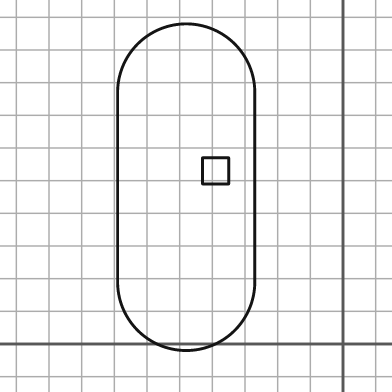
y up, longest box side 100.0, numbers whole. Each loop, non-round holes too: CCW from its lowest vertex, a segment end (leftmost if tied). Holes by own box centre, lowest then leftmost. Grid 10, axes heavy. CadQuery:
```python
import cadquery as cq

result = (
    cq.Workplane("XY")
    .moveTo(-69.0, 19.0)
    .threePointArc((-48.0, -2.0), (-27.0, 19.0))
    .lineTo(-27.0, 77.0)
    .threePointArc((-48.0, 98.0), (-69.0, 77.0))
    .close()
    .moveTo(-43.0, 49.0)
    .lineTo(-35.0, 49.0)
    .lineTo(-35.0, 57.0)
    .lineTo(-43.0, 57.0)
    .close()
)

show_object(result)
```